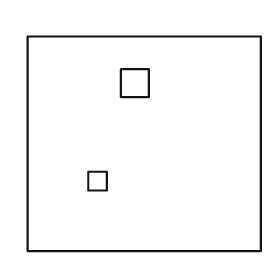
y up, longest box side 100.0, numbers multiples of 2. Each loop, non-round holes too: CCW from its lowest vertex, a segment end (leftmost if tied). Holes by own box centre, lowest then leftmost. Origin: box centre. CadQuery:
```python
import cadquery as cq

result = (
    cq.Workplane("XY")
    .moveTo(-50.0, -46.0)
    .lineTo(50.0, -46.0)
    .lineTo(50.0, 46.0)
    .lineTo(-50.0, 46.0)
    .close()
    .moveTo(-24.0, -20.0)
    .lineTo(-16.0, -20.0)
    .lineTo(-16.0, -12.0)
    .lineTo(-24.0, -12.0)
    .close()
    .moveTo(-10.0, 20.0)
    .lineTo(2.0, 20.0)
    .lineTo(2.0, 32.0)
    .lineTo(-10.0, 32.0)
    .close()
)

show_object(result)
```